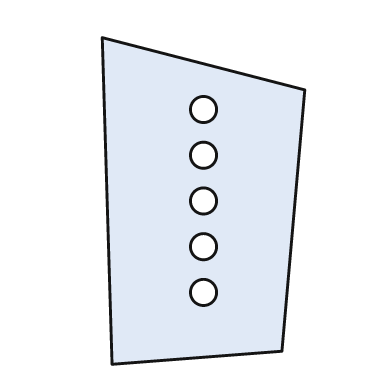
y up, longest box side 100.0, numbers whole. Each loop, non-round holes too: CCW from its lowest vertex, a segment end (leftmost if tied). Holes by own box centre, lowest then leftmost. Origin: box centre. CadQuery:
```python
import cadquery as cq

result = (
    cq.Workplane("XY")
    .moveTo(-28.0, -50.0)
    .lineTo(24.0, -46.0)
    .lineTo(31.0, 34.0)
    .lineTo(-31.0, 50.0)
    .close()
    .moveTo(0.0, -28.0)
    .circle(4.0)
    .moveTo(0.0, -14.0)
    .circle(4.0)
    .moveTo(0.0, 0.0)
    .circle(4.0)
    .moveTo(0.0, 14.0)
    .circle(4.0)
    .moveTo(0.0, 28.0)
    .circle(4.0)
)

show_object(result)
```